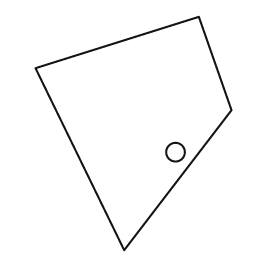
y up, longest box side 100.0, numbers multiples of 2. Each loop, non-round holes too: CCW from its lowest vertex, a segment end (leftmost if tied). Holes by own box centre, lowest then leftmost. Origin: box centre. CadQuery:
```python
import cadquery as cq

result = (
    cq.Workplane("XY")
    .moveTo(-4.0, -50.0)
    .lineTo(42.0, 10.0)
    .lineTo(28.0, 50.0)
    .lineTo(-42.0, 28.0)
    .close()
    .moveTo(18.0, -8.0)
    .circle(4.0)
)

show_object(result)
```